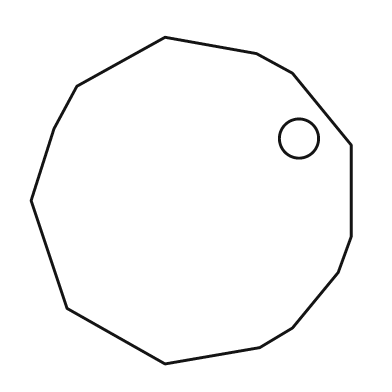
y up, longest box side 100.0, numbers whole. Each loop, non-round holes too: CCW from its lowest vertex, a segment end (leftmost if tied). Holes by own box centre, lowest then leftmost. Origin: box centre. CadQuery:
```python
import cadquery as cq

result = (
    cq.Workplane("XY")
    .moveTo(-8.0, -50.0)
    .lineTo(21.0, -45.0)
    .lineTo(31.0, -39.0)
    .lineTo(45.0, -22.0)
    .lineTo(49.0, -11.0)
    .lineTo(49.0, 17.0)
    .lineTo(31.0, 39.0)
    .lineTo(20.0, 45.0)
    .lineTo(-8.0, 50.0)
    .lineTo(-35.0, 35.0)
    .lineTo(-42.0, 22.0)
    .lineTo(-49.0, 0.0)
    .lineTo(-38.0, -33.0)
    .close()
    .moveTo(33.0, 19.0)
    .circle(6.0)
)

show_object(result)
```